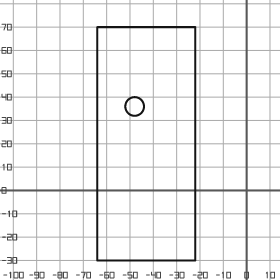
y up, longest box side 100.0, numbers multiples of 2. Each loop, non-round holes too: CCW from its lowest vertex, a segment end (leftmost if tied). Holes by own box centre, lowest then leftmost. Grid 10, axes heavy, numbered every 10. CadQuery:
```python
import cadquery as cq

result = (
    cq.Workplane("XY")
    .moveTo(-64.0, -30.0)
    .lineTo(-22.0, -30.0)
    .lineTo(-22.0, 70.0)
    .lineTo(-64.0, 70.0)
    .close()
    .moveTo(-48.0, 36.0)
    .circle(4.0)
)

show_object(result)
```